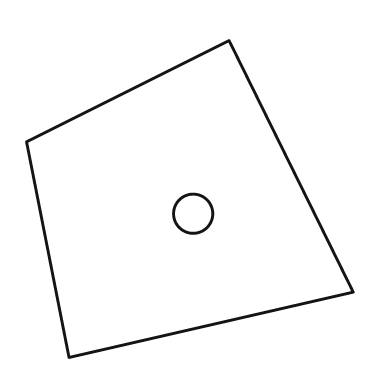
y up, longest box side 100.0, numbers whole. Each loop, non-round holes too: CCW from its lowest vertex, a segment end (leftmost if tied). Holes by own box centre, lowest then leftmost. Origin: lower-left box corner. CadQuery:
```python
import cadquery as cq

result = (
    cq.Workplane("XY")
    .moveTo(13.0, 0.0)
    .lineTo(100.0, 20.0)
    .lineTo(62.0, 97.0)
    .lineTo(0.0, 66.0)
    .close()
    .moveTo(51.0, 44.0)
    .circle(6.0)
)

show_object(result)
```